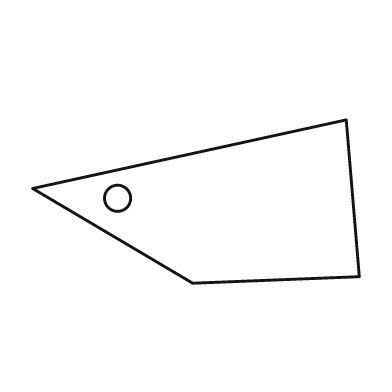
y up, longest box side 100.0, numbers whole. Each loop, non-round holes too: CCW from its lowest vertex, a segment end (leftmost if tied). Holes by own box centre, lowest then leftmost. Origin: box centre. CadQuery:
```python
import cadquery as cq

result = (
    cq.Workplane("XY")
    .moveTo(-1.0, -25.0)
    .lineTo(50.0, -23.0)
    .lineTo(46.0, 25.0)
    .lineTo(-50.0, 4.0)
    .close()
    .moveTo(-24.0, 1.0)
    .circle(4.0)
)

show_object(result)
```